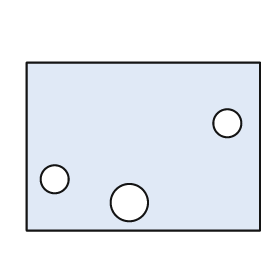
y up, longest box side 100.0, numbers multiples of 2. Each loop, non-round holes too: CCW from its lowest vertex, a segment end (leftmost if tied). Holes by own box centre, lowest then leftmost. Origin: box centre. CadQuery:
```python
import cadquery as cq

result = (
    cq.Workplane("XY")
    .moveTo(-50.0, -36.0)
    .lineTo(50.0, -36.0)
    .lineTo(50.0, 36.0)
    .lineTo(-50.0, 36.0)
    .close()
    .moveTo(-6.0, -24.0)
    .circle(8.0)
    .moveTo(-38.0, -14.0)
    .circle(6.0)
    .moveTo(36.0, 10.0)
    .circle(6.0)
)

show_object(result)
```